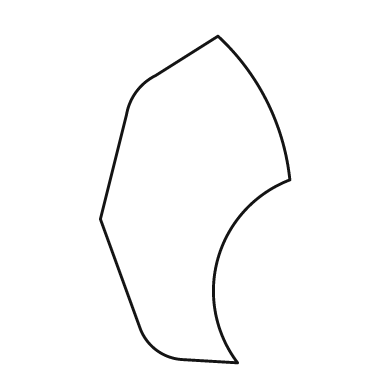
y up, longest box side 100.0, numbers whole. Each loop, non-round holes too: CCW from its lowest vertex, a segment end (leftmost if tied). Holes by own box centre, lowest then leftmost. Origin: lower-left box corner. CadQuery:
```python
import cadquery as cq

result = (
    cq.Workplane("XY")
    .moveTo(42.0, 0.0)
    .threePointArc((36.0, 32.0), (58.0, 56.0))
    .threePointArc((51.0, 80.0), (36.0, 100.0))
    .lineTo(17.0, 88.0)
    .threePointArc((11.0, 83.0), (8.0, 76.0))
    .lineTo(0.0, 44.0)
    .lineTo(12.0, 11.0)
    .threePointArc((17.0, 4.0), (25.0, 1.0))
    .close()
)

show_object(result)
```